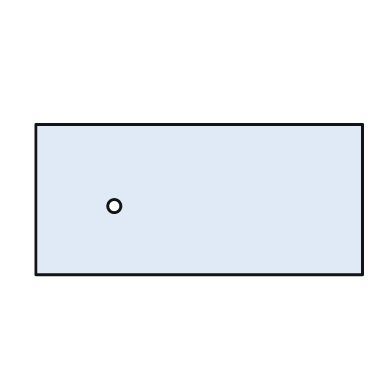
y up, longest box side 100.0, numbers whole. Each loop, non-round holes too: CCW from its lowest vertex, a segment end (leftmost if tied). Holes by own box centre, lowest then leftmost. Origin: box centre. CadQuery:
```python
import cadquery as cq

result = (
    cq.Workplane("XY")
    .moveTo(-50.0, -23.0)
    .lineTo(50.0, -23.0)
    .lineTo(50.0, 23.0)
    .lineTo(-50.0, 23.0)
    .close()
    .moveTo(-26.0, -2.0)
    .circle(2.0)
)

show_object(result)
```